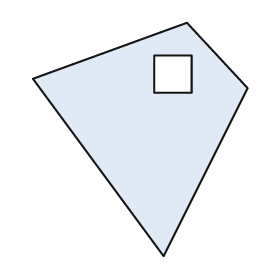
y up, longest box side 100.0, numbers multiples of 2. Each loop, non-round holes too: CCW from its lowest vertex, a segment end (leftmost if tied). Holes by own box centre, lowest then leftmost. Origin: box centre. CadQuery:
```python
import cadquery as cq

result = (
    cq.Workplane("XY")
    .moveTo(10.0, -50.0)
    .lineTo(46.0, 22.0)
    .lineTo(20.0, 50.0)
    .lineTo(-46.0, 26.0)
    .close()
    .moveTo(6.0, 20.0)
    .lineTo(22.0, 20.0)
    .lineTo(22.0, 36.0)
    .lineTo(6.0, 36.0)
    .close()
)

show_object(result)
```